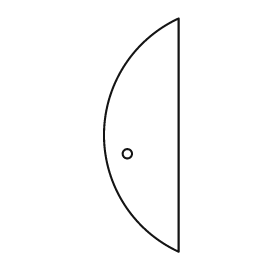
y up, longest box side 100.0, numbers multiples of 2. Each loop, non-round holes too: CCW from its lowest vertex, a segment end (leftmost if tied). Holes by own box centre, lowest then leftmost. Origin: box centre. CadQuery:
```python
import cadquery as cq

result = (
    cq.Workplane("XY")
    .moveTo(16.0, -50.0)
    .lineTo(16.0, 50.0)
    .threePointArc((-16.0, 0.0), (16.0, -50.0))
    .close()
    .moveTo(-6.0, -8.0)
    .circle(2.0)
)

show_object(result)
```